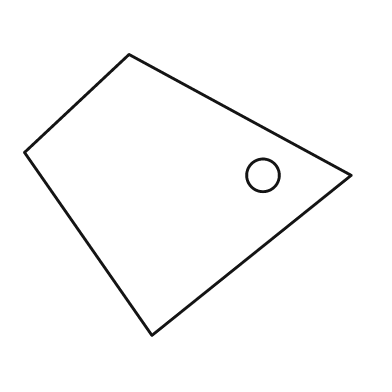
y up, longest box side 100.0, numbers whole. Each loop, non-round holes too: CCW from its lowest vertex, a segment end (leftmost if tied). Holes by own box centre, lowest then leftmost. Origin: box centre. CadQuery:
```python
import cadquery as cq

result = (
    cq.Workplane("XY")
    .moveTo(-11.0, -43.0)
    .lineTo(50.0, 6.0)
    .lineTo(-18.0, 43.0)
    .lineTo(-50.0, 13.0)
    .close()
    .moveTo(23.0, 6.0)
    .circle(5.0)
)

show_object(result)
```